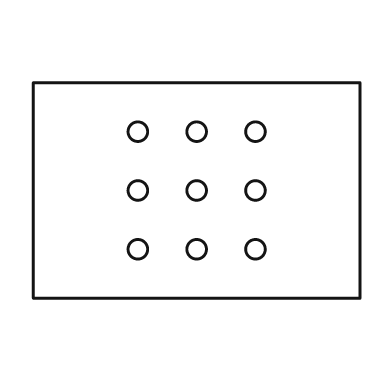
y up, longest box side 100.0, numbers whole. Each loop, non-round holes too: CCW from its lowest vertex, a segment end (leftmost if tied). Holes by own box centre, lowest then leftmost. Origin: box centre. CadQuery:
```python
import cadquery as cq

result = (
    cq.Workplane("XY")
    .moveTo(-50.0, -33.0)
    .lineTo(50.0, -33.0)
    .lineTo(50.0, 33.0)
    .lineTo(-50.0, 33.0)
    .close()
    .moveTo(-18.0, -18.0)
    .circle(3.0)
    .moveTo(0.0, -18.0)
    .circle(3.0)
    .moveTo(18.0, -18.0)
    .circle(3.0)
    .moveTo(-18.0, 0.0)
    .circle(3.0)
    .moveTo(0.0, 0.0)
    .circle(3.0)
    .moveTo(18.0, 0.0)
    .circle(3.0)
    .moveTo(-18.0, 18.0)
    .circle(3.0)
    .moveTo(0.0, 18.0)
    .circle(3.0)
    .moveTo(18.0, 18.0)
    .circle(3.0)
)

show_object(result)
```